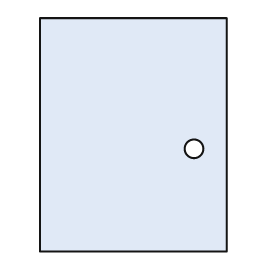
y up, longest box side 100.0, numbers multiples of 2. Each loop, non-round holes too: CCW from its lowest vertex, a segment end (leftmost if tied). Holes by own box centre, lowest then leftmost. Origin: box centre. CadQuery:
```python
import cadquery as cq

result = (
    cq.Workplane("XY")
    .moveTo(-40.0, -50.0)
    .lineTo(40.0, -50.0)
    .lineTo(40.0, 50.0)
    .lineTo(-40.0, 50.0)
    .close()
    .moveTo(26.0, -6.0)
    .circle(4.0)
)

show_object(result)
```